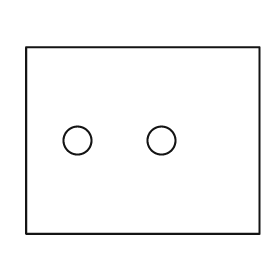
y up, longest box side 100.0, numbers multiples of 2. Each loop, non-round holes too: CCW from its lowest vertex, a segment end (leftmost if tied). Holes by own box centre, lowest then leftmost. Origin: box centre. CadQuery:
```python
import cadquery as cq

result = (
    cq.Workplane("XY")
    .moveTo(-50.0, -40.0)
    .lineTo(50.0, -40.0)
    .lineTo(50.0, 40.0)
    .lineTo(-50.0, 40.0)
    .close()
    .moveTo(-28.0, 0.0)
    .circle(6.0)
    .moveTo(8.0, 0.0)
    .circle(6.0)
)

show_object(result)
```